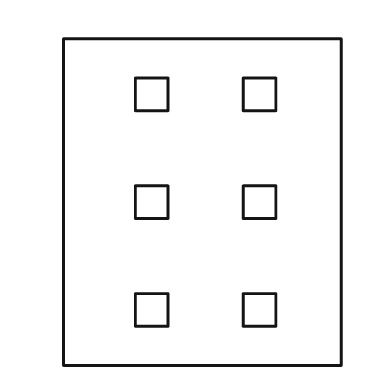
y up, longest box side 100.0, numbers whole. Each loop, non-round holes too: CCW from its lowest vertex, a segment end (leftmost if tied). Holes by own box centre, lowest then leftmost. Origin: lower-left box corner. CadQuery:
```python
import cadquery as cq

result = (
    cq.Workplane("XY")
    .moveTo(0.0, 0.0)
    .lineTo(85.0, 0.0)
    .lineTo(85.0, 100.0)
    .lineTo(0.0, 100.0)
    .close()
    .moveTo(22.0, 12.0)
    .lineTo(32.0, 12.0)
    .lineTo(32.0, 22.0)
    .lineTo(22.0, 22.0)
    .close()
    .moveTo(55.0, 12.0)
    .lineTo(65.0, 12.0)
    .lineTo(65.0, 22.0)
    .lineTo(55.0, 22.0)
    .close()
    .moveTo(22.0, 45.0)
    .lineTo(32.0, 45.0)
    .lineTo(32.0, 55.0)
    .lineTo(22.0, 55.0)
    .close()
    .moveTo(55.0, 45.0)
    .lineTo(65.0, 45.0)
    .lineTo(65.0, 55.0)
    .lineTo(55.0, 55.0)
    .close()
    .moveTo(22.0, 78.0)
    .lineTo(32.0, 78.0)
    .lineTo(32.0, 88.0)
    .lineTo(22.0, 88.0)
    .close()
    .moveTo(55.0, 78.0)
    .lineTo(65.0, 78.0)
    .lineTo(65.0, 88.0)
    .lineTo(55.0, 88.0)
    .close()
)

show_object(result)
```